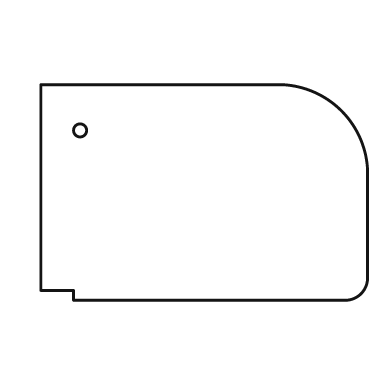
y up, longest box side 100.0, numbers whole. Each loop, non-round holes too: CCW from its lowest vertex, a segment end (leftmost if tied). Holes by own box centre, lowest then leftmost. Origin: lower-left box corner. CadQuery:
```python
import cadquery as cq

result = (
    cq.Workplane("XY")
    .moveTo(10.0, 0.0)
    .lineTo(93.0, 0.0)
    .threePointArc((98.0, 2.0), (100.0, 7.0))
    .lineTo(100.0, 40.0)
    .threePointArc((92.0, 58.0), (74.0, 66.0))
    .lineTo(0.0, 66.0)
    .lineTo(0.0, 3.0)
    .lineTo(10.0, 3.0)
    .close()
    .moveTo(12.0, 52.0)
    .circle(2.0)
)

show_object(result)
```